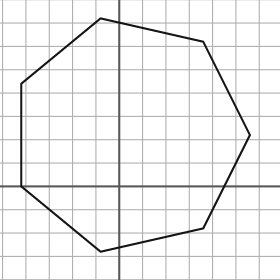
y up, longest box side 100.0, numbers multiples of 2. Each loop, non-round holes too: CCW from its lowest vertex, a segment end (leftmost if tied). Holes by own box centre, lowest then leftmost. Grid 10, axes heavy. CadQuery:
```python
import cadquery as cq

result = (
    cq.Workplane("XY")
    .moveTo(-8.0, -28.0)
    .lineTo(36.0, -18.0)
    .lineTo(56.0, 22.0)
    .lineTo(36.0, 62.0)
    .lineTo(-8.0, 72.0)
    .lineTo(-42.0, 44.0)
    .lineTo(-42.0, 0.0)
    .close()
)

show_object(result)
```